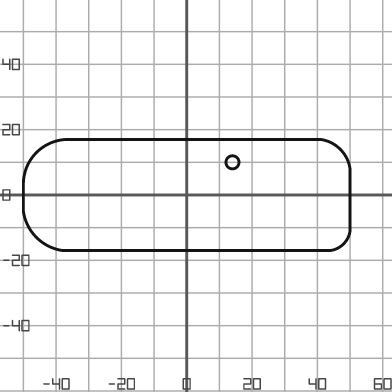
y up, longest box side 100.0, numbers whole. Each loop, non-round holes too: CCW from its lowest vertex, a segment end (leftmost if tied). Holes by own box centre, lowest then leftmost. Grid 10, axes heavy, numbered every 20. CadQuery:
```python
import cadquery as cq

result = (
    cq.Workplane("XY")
    .moveTo(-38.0, -17.0)
    .lineTo(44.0, -17.0)
    .threePointArc((48.0, -15.0), (50.0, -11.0))
    .lineTo(50.0, 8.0)
    .threePointArc((47.0, 14.0), (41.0, 17.0))
    .lineTo(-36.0, 17.0)
    .threePointArc((-46.0, 13.0), (-50.0, 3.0))
    .lineTo(-50.0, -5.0)
    .threePointArc((-46.0, -13.0), (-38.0, -17.0))
    .close()
    .moveTo(14.0, 10.0)
    .circle(2.0)
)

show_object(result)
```